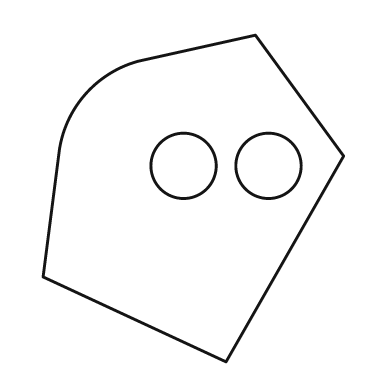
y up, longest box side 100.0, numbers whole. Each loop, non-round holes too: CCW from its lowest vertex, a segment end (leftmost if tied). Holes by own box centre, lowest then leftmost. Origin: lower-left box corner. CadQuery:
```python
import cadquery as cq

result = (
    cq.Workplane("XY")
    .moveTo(56.0, 0.0)
    .lineTo(92.0, 63.0)
    .lineTo(65.0, 100.0)
    .lineTo(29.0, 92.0)
    .threePointArc((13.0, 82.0), (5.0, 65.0))
    .lineTo(0.0, 26.0)
    .close()
    .moveTo(43.0, 60.0)
    .circle(10.0)
    .moveTo(69.0, 60.0)
    .circle(10.0)
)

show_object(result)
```